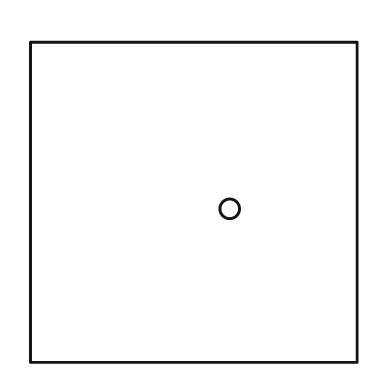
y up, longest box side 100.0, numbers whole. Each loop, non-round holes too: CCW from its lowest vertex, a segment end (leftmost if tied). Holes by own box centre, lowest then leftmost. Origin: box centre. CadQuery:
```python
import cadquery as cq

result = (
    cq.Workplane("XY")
    .moveTo(-50.0, -49.0)
    .lineTo(50.0, -49.0)
    .lineTo(50.0, 49.0)
    .lineTo(-50.0, 49.0)
    .close()
    .moveTo(11.0, -2.0)
    .circle(3.0)
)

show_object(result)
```